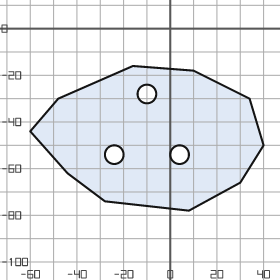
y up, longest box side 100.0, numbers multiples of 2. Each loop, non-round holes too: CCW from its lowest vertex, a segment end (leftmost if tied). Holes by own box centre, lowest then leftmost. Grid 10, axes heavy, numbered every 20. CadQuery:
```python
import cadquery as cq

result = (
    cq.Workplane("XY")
    .moveTo(8.0, -78.0)
    .lineTo(30.0, -66.0)
    .lineTo(40.0, -50.0)
    .lineTo(34.0, -30.0)
    .lineTo(10.0, -18.0)
    .lineTo(-16.0, -16.0)
    .lineTo(-48.0, -30.0)
    .lineTo(-60.0, -44.0)
    .lineTo(-44.0, -62.0)
    .lineTo(-28.0, -74.0)
    .close()
    .moveTo(-24.0, -54.0)
    .circle(4.0)
    .moveTo(4.0, -54.0)
    .circle(4.0)
    .moveTo(-10.0, -28.0)
    .circle(4.0)
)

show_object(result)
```